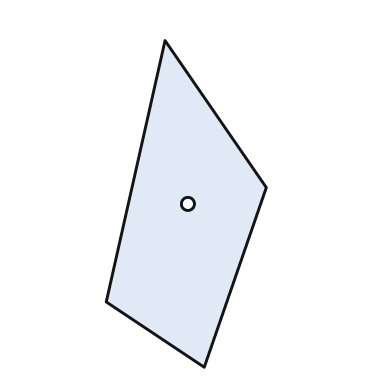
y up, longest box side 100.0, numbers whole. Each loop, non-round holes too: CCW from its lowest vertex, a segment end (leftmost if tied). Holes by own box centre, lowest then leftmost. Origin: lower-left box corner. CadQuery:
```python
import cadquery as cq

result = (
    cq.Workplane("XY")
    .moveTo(30.0, 0.0)
    .lineTo(49.0, 55.0)
    .lineTo(18.0, 100.0)
    .lineTo(0.0, 20.0)
    .close()
    .moveTo(25.0, 50.0)
    .circle(2.0)
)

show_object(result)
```